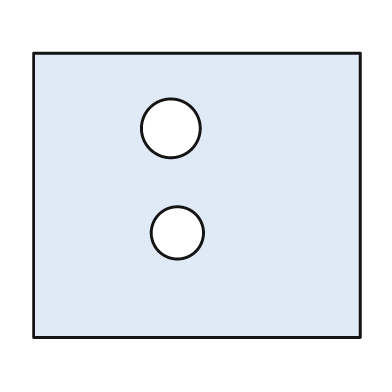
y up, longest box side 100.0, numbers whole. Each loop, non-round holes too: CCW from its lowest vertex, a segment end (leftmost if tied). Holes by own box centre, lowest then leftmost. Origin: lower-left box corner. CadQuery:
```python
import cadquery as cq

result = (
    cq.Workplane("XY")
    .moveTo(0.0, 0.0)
    .lineTo(100.0, 0.0)
    .lineTo(100.0, 87.0)
    .lineTo(0.0, 87.0)
    .close()
    .moveTo(44.0, 32.0)
    .circle(8.0)
    .moveTo(42.0, 64.0)
    .circle(9.0)
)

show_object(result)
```